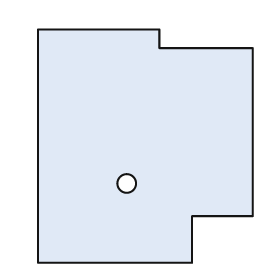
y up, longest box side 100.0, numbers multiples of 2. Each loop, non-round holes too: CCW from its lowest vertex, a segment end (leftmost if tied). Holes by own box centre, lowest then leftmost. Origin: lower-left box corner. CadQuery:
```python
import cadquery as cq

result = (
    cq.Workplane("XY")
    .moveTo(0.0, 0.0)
    .lineTo(66.0, 0.0)
    .lineTo(66.0, 20.0)
    .lineTo(92.0, 20.0)
    .lineTo(92.0, 92.0)
    .lineTo(52.0, 92.0)
    .lineTo(52.0, 100.0)
    .lineTo(0.0, 100.0)
    .close()
    .moveTo(38.0, 34.0)
    .circle(4.0)
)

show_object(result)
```